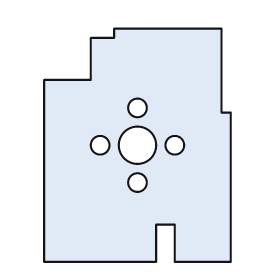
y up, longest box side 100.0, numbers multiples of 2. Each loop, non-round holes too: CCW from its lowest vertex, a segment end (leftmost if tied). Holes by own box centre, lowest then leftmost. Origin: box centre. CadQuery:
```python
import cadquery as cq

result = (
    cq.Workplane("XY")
    .moveTo(-40.0, -50.0)
    .lineTo(8.0, -50.0)
    .lineTo(8.0, -34.0)
    .lineTo(16.0, -34.0)
    .lineTo(16.0, -50.0)
    .lineTo(40.0, -50.0)
    .lineTo(40.0, 14.0)
    .lineTo(36.0, 14.0)
    .lineTo(36.0, 50.0)
    .lineTo(-10.0, 50.0)
    .lineTo(-10.0, 46.0)
    .lineTo(-20.0, 46.0)
    .lineTo(-20.0, 28.0)
    .lineTo(-40.0, 28.0)
    .close()
    .moveTo(0.0, -16.0)
    .circle(4.0)
    .moveTo(-16.0, 0.0)
    .circle(4.0)
    .moveTo(0.0, 0.0)
    .circle(8.0)
    .moveTo(16.0, 0.0)
    .circle(4.0)
    .moveTo(0.0, 16.0)
    .circle(4.0)
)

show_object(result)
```